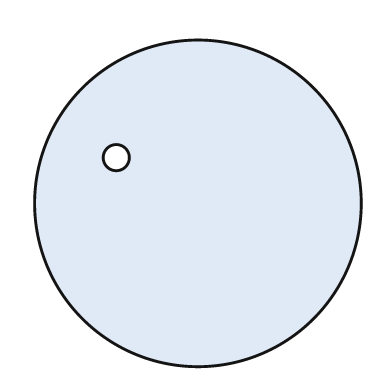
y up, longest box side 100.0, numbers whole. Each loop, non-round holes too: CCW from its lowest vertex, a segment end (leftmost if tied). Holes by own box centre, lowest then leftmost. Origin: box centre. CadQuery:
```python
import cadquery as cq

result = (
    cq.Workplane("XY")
    .moveTo(0.0, 0.0)
    .circle(50.0)
    .moveTo(-25.0, 14.0)
    .circle(4.0)
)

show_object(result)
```